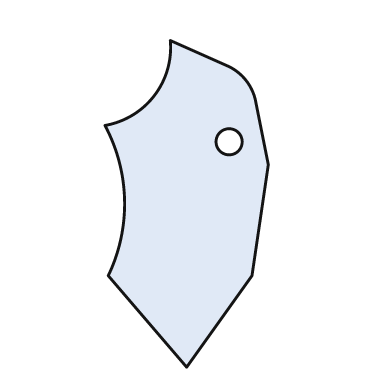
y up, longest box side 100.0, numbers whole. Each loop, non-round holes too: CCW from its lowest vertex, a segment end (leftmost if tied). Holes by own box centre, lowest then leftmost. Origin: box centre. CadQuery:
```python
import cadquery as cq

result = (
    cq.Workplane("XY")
    .moveTo(0.0, -50.0)
    .lineTo(20.0, -22.0)
    .lineTo(25.0, 12.0)
    .lineTo(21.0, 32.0)
    .threePointArc((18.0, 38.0), (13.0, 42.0))
    .lineTo(-5.0, 50.0)
    .threePointArc((-10.0, 33.0), (-25.0, 24.0))
    .threePointArc((-19.0, 1.0), (-24.0, -22.0))
    .close()
    .moveTo(13.0, 19.0)
    .circle(4.0)
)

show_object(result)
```